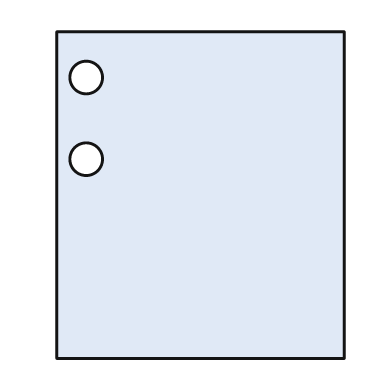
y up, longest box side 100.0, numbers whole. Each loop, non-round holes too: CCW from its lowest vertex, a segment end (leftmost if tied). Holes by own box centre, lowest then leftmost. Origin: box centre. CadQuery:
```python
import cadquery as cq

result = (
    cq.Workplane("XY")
    .moveTo(-44.0, -50.0)
    .lineTo(44.0, -50.0)
    .lineTo(44.0, 50.0)
    .lineTo(-44.0, 50.0)
    .close()
    .moveTo(-35.0, 11.0)
    .circle(5.0)
    .moveTo(-35.0, 36.0)
    .circle(5.0)
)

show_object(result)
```